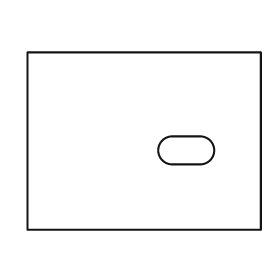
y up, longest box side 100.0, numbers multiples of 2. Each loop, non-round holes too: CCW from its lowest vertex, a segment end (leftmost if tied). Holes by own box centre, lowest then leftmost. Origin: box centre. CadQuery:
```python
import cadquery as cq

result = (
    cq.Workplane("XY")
    .moveTo(-50.0, -38.0)
    .lineTo(50.0, -38.0)
    .lineTo(50.0, 38.0)
    .lineTo(-50.0, 38.0)
    .close()
    .moveTo(12.0, -10.0)
    .lineTo(24.0, -10.0)
    .threePointArc((30.0, -4.0), (24.0, 2.0))
    .lineTo(12.0, 2.0)
    .threePointArc((6.0, -4.0), (12.0, -10.0))
    .close()
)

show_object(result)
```